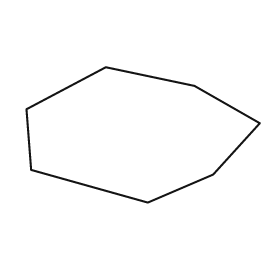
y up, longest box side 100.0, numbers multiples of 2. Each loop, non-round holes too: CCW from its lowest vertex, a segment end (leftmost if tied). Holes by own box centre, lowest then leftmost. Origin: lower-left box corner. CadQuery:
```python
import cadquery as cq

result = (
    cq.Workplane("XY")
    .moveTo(52.0, 0.0)
    .lineTo(80.0, 12.0)
    .lineTo(100.0, 34.0)
    .lineTo(72.0, 50.0)
    .lineTo(34.0, 58.0)
    .lineTo(0.0, 40.0)
    .lineTo(2.0, 14.0)
    .close()
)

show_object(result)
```